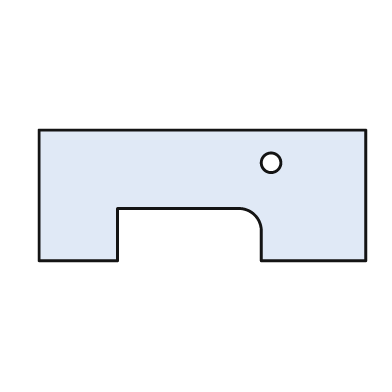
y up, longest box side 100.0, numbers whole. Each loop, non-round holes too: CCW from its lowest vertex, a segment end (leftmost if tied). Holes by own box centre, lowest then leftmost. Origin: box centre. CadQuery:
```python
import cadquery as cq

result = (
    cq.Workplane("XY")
    .moveTo(-50.0, -20.0)
    .lineTo(-26.0, -20.0)
    .lineTo(-26.0, -4.0)
    .lineTo(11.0, -4.0)
    .threePointArc((16.0, -6.0), (18.0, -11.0))
    .lineTo(18.0, -20.0)
    .lineTo(50.0, -20.0)
    .lineTo(50.0, 20.0)
    .lineTo(-50.0, 20.0)
    .close()
    .moveTo(21.0, 10.0)
    .circle(3.0)
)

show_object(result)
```